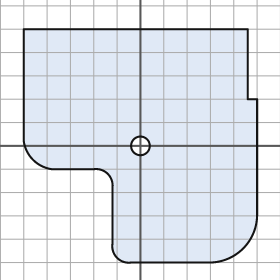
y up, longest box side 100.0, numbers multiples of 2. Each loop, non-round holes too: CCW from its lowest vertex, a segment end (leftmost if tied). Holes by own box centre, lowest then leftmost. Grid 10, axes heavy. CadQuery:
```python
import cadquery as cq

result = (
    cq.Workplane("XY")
    .moveTo(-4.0, -50.0)
    .lineTo(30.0, -50.0)
    .threePointArc((44.0, -44.0), (50.0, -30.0))
    .lineTo(50.0, 20.0)
    .lineTo(46.0, 20.0)
    .lineTo(46.0, 50.0)
    .lineTo(-50.0, 50.0)
    .lineTo(-50.0, 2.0)
    .threePointArc((-46.0, -6.0), (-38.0, -10.0))
    .lineTo(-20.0, -10.0)
    .threePointArc((-14.0, -12.0), (-12.0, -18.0))
    .lineTo(-12.0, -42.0)
    .threePointArc((-10.0, -48.0), (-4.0, -50.0))
    .close()
    .moveTo(0.0, 0.0)
    .circle(4.0)
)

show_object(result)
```